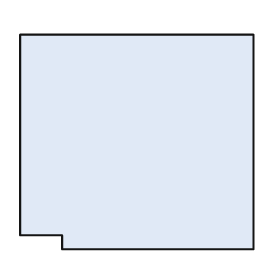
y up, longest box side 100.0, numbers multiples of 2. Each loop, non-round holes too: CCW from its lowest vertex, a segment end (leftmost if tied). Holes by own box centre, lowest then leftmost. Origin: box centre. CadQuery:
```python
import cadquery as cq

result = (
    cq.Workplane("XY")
    .moveTo(-32.0, -46.0)
    .lineTo(50.0, -46.0)
    .lineTo(50.0, 46.0)
    .lineTo(-50.0, 46.0)
    .lineTo(-50.0, -40.0)
    .lineTo(-32.0, -40.0)
    .close()
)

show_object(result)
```